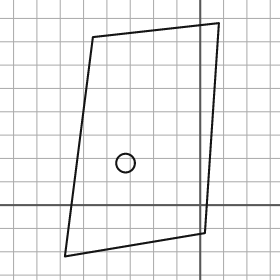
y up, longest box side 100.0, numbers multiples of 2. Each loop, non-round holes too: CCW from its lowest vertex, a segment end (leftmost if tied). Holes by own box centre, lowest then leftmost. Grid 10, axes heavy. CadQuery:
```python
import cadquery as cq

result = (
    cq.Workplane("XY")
    .moveTo(-58.0, -22.0)
    .lineTo(2.0, -12.0)
    .lineTo(8.0, 78.0)
    .lineTo(-46.0, 72.0)
    .close()
    .moveTo(-32.0, 18.0)
    .circle(4.0)
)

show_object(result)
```